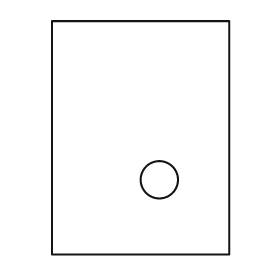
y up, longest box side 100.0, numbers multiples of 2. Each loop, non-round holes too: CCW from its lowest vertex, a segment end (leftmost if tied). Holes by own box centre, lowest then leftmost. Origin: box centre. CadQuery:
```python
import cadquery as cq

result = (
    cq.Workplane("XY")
    .moveTo(-38.0, -50.0)
    .lineTo(38.0, -50.0)
    .lineTo(38.0, 50.0)
    .lineTo(-38.0, 50.0)
    .close()
    .moveTo(8.0, -18.0)
    .circle(8.0)
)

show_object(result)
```